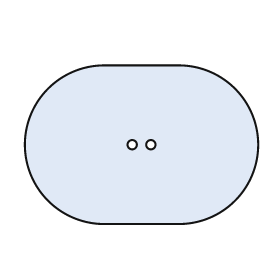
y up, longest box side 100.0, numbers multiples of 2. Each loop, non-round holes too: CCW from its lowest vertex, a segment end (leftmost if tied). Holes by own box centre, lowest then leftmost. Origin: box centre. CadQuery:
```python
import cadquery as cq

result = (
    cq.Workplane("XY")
    .moveTo(-16.0, -34.0)
    .lineTo(16.0, -34.0)
    .threePointArc((50.0, 0.0), (16.0, 34.0))
    .lineTo(-16.0, 34.0)
    .threePointArc((-50.0, 0.0), (-16.0, -34.0))
    .close()
    .moveTo(-4.0, 0.0)
    .circle(2.0)
    .moveTo(4.0, 0.0)
    .circle(2.0)
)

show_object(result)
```